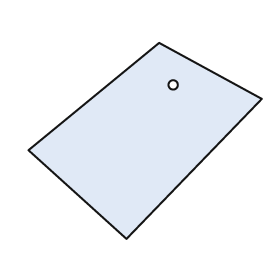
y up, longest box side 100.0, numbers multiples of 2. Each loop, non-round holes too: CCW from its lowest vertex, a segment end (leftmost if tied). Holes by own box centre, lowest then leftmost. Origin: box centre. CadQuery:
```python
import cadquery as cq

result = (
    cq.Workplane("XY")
    .moveTo(-8.0, -42.0)
    .lineTo(50.0, 18.0)
    .lineTo(6.0, 42.0)
    .lineTo(-50.0, -4.0)
    .close()
    .moveTo(12.0, 24.0)
    .circle(2.0)
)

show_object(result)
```